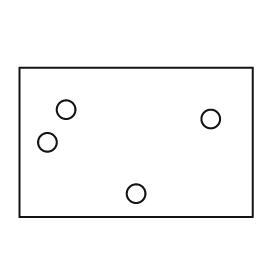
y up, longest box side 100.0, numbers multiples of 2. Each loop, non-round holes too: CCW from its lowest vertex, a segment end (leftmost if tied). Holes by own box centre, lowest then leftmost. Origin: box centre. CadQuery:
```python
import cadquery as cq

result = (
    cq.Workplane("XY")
    .moveTo(-50.0, -32.0)
    .lineTo(50.0, -32.0)
    .lineTo(50.0, 32.0)
    .lineTo(-50.0, 32.0)
    .close()
    .moveTo(0.0, -22.0)
    .circle(4.0)
    .moveTo(-38.0, 0.0)
    .circle(4.0)
    .moveTo(32.0, 10.0)
    .circle(4.0)
    .moveTo(-30.0, 14.0)
    .circle(4.0)
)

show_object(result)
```